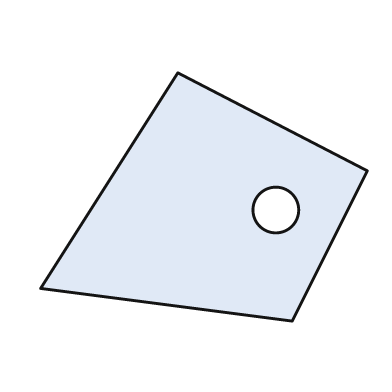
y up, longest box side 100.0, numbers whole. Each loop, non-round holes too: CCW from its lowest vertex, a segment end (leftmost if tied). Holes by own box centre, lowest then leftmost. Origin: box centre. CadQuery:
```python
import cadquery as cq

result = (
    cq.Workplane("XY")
    .moveTo(27.0, -38.0)
    .lineTo(50.0, 8.0)
    .lineTo(-8.0, 38.0)
    .lineTo(-50.0, -28.0)
    .close()
    .moveTo(22.0, -4.0)
    .circle(7.0)
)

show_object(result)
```